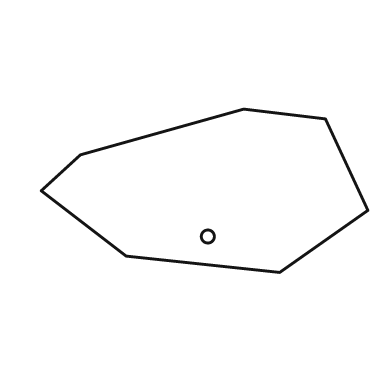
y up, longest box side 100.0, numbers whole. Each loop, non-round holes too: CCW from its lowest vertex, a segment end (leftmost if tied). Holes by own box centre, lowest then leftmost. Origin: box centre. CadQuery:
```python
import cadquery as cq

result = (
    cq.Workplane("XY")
    .moveTo(23.0, -25.0)
    .lineTo(50.0, -6.0)
    .lineTo(37.0, 22.0)
    .lineTo(12.0, 25.0)
    .lineTo(-38.0, 11.0)
    .lineTo(-50.0, 0.0)
    .lineTo(-24.0, -20.0)
    .close()
    .moveTo(1.0, -14.0)
    .circle(2.0)
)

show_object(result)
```